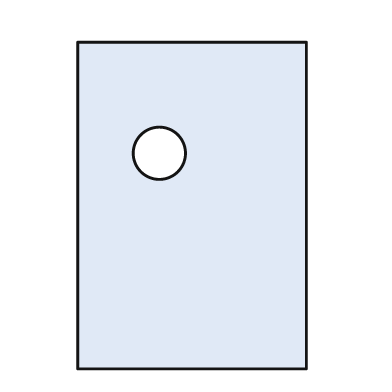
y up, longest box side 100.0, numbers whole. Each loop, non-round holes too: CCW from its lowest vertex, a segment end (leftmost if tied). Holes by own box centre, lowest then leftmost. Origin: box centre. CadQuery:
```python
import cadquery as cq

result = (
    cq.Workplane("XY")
    .moveTo(-35.0, -50.0)
    .lineTo(35.0, -50.0)
    .lineTo(35.0, 50.0)
    .lineTo(-35.0, 50.0)
    .close()
    .moveTo(-10.0, 16.0)
    .circle(8.0)
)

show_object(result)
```